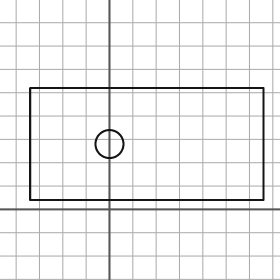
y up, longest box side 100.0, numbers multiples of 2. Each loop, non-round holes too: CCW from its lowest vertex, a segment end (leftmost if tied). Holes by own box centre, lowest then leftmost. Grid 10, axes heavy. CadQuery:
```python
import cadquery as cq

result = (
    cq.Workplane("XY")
    .moveTo(-34.0, 4.0)
    .lineTo(66.0, 4.0)
    .lineTo(66.0, 52.0)
    .lineTo(-34.0, 52.0)
    .close()
    .moveTo(0.0, 28.0)
    .circle(6.0)
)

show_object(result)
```